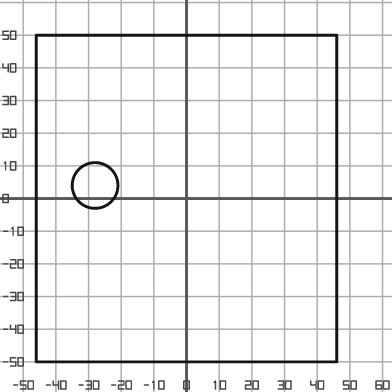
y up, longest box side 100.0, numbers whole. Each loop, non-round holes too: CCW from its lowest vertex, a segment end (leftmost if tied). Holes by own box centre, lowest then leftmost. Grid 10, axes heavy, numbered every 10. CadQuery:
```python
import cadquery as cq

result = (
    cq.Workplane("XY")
    .moveTo(-46.0, -50.0)
    .lineTo(46.0, -50.0)
    .lineTo(46.0, 50.0)
    .lineTo(-46.0, 50.0)
    .close()
    .moveTo(-28.0, 4.0)
    .circle(7.0)
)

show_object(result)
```